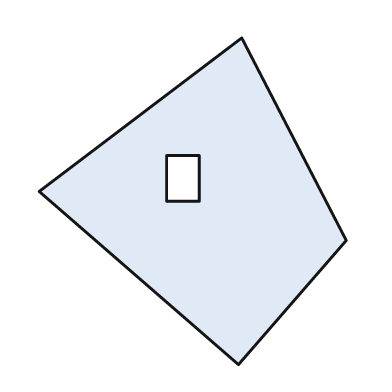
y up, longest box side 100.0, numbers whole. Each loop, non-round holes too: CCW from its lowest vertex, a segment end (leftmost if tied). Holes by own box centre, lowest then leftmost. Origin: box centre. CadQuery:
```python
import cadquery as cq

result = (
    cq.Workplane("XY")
    .moveTo(14.0, -50.0)
    .lineTo(47.0, -12.0)
    .lineTo(15.0, 50.0)
    .lineTo(-47.0, 3.0)
    .close()
    .moveTo(-8.0, 0.0)
    .lineTo(2.0, 0.0)
    .lineTo(2.0, 14.0)
    .lineTo(-8.0, 14.0)
    .close()
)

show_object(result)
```